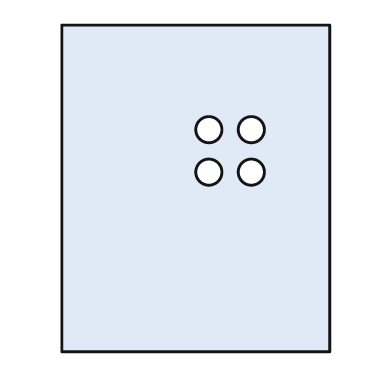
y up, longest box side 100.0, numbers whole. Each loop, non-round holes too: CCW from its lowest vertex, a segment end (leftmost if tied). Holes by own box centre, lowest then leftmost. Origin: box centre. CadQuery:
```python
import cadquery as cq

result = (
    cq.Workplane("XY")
    .moveTo(-41.0, -50.0)
    .lineTo(41.0, -50.0)
    .lineTo(41.0, 50.0)
    .lineTo(-41.0, 50.0)
    .close()
    .moveTo(4.0, 5.0)
    .circle(4.0)
    .moveTo(17.0, 5.0)
    .circle(4.0)
    .moveTo(4.0, 18.0)
    .circle(4.0)
    .moveTo(17.0, 18.0)
    .circle(4.0)
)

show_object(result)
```